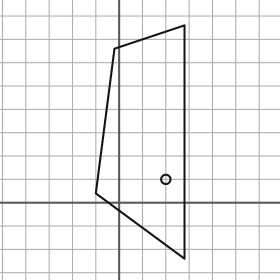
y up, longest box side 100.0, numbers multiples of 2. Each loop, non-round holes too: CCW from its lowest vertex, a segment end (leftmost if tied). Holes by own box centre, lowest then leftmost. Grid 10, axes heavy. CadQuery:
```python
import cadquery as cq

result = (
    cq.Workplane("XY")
    .moveTo(28.0, -24.0)
    .lineTo(28.0, 76.0)
    .lineTo(-2.0, 66.0)
    .lineTo(-10.0, 4.0)
    .close()
    .moveTo(20.0, 10.0)
    .circle(2.0)
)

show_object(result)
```